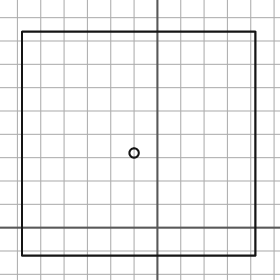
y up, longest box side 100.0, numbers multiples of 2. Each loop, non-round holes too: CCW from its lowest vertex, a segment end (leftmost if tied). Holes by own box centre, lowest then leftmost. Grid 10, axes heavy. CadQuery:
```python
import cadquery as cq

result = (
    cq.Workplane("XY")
    .moveTo(-58.0, -12.0)
    .lineTo(42.0, -12.0)
    .lineTo(42.0, 84.0)
    .lineTo(-58.0, 84.0)
    .close()
    .moveTo(-10.0, 32.0)
    .circle(2.0)
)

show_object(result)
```